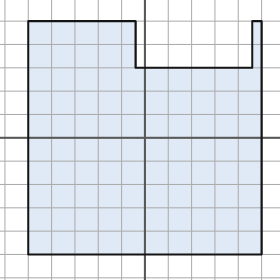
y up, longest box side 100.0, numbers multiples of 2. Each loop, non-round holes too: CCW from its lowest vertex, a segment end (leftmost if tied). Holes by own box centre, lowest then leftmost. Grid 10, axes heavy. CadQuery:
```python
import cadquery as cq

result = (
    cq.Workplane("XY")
    .moveTo(-50.0, -50.0)
    .lineTo(50.0, -50.0)
    .lineTo(50.0, 50.0)
    .lineTo(46.0, 50.0)
    .lineTo(46.0, 30.0)
    .lineTo(-4.0, 30.0)
    .lineTo(-4.0, 50.0)
    .lineTo(-50.0, 50.0)
    .close()
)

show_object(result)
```